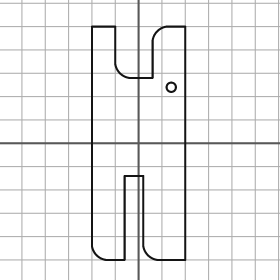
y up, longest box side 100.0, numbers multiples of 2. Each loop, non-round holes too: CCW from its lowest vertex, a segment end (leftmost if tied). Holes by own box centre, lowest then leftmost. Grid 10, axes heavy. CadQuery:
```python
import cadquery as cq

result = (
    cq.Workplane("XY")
    .moveTo(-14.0, -50.0)
    .lineTo(-6.0, -50.0)
    .lineTo(-6.0, -14.0)
    .lineTo(2.0, -14.0)
    .lineTo(2.0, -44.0)
    .threePointArc((4.0, -48.0), (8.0, -50.0))
    .lineTo(20.0, -50.0)
    .lineTo(20.0, 50.0)
    .lineTo(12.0, 50.0)
    .threePointArc((8.0, 48.0), (6.0, 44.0))
    .lineTo(6.0, 28.0)
    .lineTo(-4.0, 28.0)
    .threePointArc((-8.0, 30.0), (-10.0, 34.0))
    .lineTo(-10.0, 50.0)
    .lineTo(-20.0, 50.0)
    .lineTo(-20.0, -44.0)
    .threePointArc((-18.0, -48.0), (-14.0, -50.0))
    .close()
    .moveTo(14.0, 24.0)
    .circle(2.0)
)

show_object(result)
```